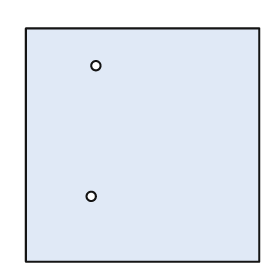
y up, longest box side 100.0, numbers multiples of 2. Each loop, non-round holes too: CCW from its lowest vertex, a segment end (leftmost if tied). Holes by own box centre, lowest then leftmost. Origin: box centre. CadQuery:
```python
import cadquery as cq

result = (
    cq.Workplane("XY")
    .moveTo(-50.0, -50.0)
    .lineTo(50.0, -50.0)
    .lineTo(50.0, 50.0)
    .lineTo(-50.0, 50.0)
    .close()
    .moveTo(-22.0, -22.0)
    .circle(2.0)
    .moveTo(-20.0, 34.0)
    .circle(2.0)
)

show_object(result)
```